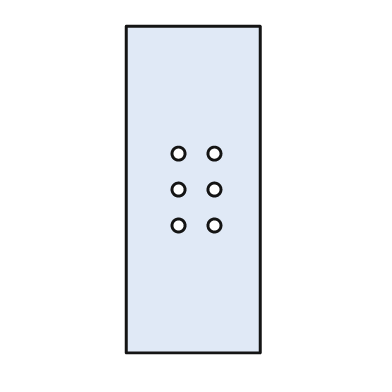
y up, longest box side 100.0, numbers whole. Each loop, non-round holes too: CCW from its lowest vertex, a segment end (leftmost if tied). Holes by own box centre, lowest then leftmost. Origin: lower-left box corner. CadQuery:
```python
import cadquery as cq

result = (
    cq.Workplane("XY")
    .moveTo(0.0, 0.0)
    .lineTo(41.0, 0.0)
    .lineTo(41.0, 100.0)
    .lineTo(0.0, 100.0)
    .close()
    .moveTo(16.0, 39.0)
    .circle(2.0)
    .moveTo(27.0, 39.0)
    .circle(2.0)
    .moveTo(16.0, 50.0)
    .circle(2.0)
    .moveTo(27.0, 50.0)
    .circle(2.0)
    .moveTo(16.0, 61.0)
    .circle(2.0)
    .moveTo(27.0, 61.0)
    .circle(2.0)
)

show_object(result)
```